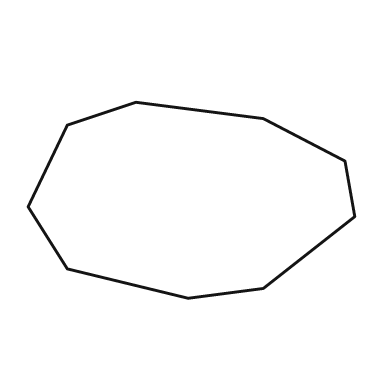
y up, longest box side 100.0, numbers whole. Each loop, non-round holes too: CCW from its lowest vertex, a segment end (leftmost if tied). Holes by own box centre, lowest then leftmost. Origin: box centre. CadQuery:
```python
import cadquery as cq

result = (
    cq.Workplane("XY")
    .moveTo(-1.0, -30.0)
    .lineTo(22.0, -27.0)
    .lineTo(50.0, -5.0)
    .lineTo(47.0, 12.0)
    .lineTo(22.0, 25.0)
    .lineTo(-17.0, 30.0)
    .lineTo(-38.0, 23.0)
    .lineTo(-50.0, -2.0)
    .lineTo(-38.0, -21.0)
    .close()
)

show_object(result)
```